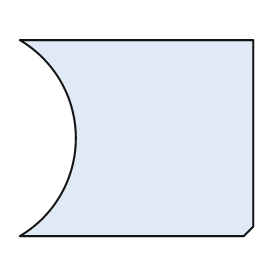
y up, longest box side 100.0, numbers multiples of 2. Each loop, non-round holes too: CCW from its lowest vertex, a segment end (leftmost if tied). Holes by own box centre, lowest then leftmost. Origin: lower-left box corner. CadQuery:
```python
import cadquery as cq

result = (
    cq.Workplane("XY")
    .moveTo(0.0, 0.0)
    .lineTo(96.0, 0.0)
    .lineTo(100.0, 4.0)
    .lineTo(100.0, 84.0)
    .lineTo(0.0, 84.0)
    .threePointArc((24.0, 42.0), (0.0, 0.0))
    .close()
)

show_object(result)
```